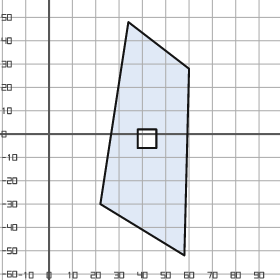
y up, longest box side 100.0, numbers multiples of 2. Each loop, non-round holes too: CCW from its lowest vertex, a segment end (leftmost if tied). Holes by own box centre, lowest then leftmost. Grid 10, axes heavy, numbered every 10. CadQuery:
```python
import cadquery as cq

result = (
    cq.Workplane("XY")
    .moveTo(58.0, -52.0)
    .lineTo(60.0, 28.0)
    .lineTo(34.0, 48.0)
    .lineTo(22.0, -30.0)
    .close()
    .moveTo(38.0, -6.0)
    .lineTo(46.0, -6.0)
    .lineTo(46.0, 2.0)
    .lineTo(38.0, 2.0)
    .close()
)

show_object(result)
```